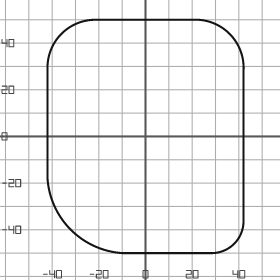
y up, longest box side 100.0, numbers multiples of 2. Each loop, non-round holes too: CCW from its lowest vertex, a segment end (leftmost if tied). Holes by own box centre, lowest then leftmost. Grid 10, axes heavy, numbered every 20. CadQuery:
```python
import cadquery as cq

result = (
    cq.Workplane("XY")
    .moveTo(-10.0, -50.0)
    .lineTo(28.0, -50.0)
    .threePointArc((38.0, -46.0), (42.0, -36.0))
    .lineTo(42.0, 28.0)
    .threePointArc((36.0, 44.0), (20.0, 50.0))
    .lineTo(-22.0, 50.0)
    .threePointArc((-36.0, 44.0), (-42.0, 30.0))
    .lineTo(-42.0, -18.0)
    .threePointArc((-32.0, -40.0), (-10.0, -50.0))
    .close()
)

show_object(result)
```